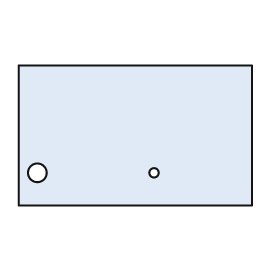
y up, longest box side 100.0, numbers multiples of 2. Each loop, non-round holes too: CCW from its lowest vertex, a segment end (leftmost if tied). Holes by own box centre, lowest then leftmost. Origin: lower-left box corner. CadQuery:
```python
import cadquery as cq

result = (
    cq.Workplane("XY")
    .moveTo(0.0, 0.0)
    .lineTo(100.0, 0.0)
    .lineTo(100.0, 60.0)
    .lineTo(0.0, 60.0)
    .close()
    .moveTo(8.0, 14.0)
    .circle(4.0)
    .moveTo(58.0, 14.0)
    .circle(2.0)
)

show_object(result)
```